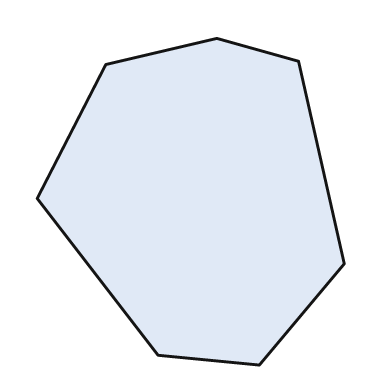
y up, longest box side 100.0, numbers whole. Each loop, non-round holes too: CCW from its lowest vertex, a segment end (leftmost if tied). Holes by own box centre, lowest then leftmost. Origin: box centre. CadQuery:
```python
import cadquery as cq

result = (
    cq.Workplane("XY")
    .moveTo(21.0, -50.0)
    .lineTo(47.0, -19.0)
    .lineTo(33.0, 43.0)
    .lineTo(8.0, 50.0)
    .lineTo(-26.0, 42.0)
    .lineTo(-47.0, 1.0)
    .lineTo(-10.0, -47.0)
    .close()
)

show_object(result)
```